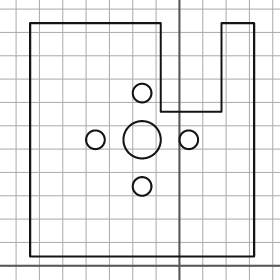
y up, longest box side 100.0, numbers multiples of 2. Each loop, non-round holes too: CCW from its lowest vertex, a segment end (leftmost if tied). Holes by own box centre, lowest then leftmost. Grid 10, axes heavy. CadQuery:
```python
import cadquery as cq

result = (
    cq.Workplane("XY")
    .moveTo(-64.0, 4.0)
    .lineTo(32.0, 4.0)
    .lineTo(32.0, 104.0)
    .lineTo(18.0, 104.0)
    .lineTo(18.0, 66.0)
    .lineTo(-8.0, 66.0)
    .lineTo(-8.0, 104.0)
    .lineTo(-64.0, 104.0)
    .close()
    .moveTo(-16.0, 34.0)
    .circle(4.0)
    .moveTo(-36.0, 54.0)
    .circle(4.0)
    .moveTo(-16.0, 54.0)
    .circle(8.0)
    .moveTo(4.0, 54.0)
    .circle(4.0)
    .moveTo(-16.0, 74.0)
    .circle(4.0)
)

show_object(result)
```